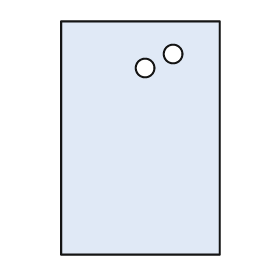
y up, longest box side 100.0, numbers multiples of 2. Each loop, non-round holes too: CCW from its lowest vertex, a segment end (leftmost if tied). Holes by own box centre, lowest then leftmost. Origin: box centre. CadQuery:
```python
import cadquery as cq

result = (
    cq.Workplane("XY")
    .moveTo(-34.0, -50.0)
    .lineTo(34.0, -50.0)
    .lineTo(34.0, 50.0)
    .lineTo(-34.0, 50.0)
    .close()
    .moveTo(2.0, 30.0)
    .circle(4.0)
    .moveTo(14.0, 36.0)
    .circle(4.0)
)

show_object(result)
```